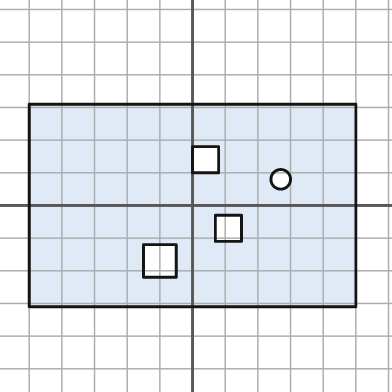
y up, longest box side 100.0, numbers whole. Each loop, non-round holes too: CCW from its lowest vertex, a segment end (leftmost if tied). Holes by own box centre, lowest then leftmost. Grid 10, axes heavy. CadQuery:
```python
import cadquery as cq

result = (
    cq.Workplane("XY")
    .moveTo(-50.0, -31.0)
    .lineTo(50.0, -31.0)
    .lineTo(50.0, 31.0)
    .lineTo(-50.0, 31.0)
    .close()
    .moveTo(-15.0, -22.0)
    .lineTo(-5.0, -22.0)
    .lineTo(-5.0, -12.0)
    .lineTo(-15.0, -12.0)
    .close()
    .moveTo(7.0, -11.0)
    .lineTo(15.0, -11.0)
    .lineTo(15.0, -3.0)
    .lineTo(7.0, -3.0)
    .close()
    .moveTo(27.0, 8.0)
    .circle(3.0)
    .moveTo(0.0, 10.0)
    .lineTo(8.0, 10.0)
    .lineTo(8.0, 18.0)
    .lineTo(0.0, 18.0)
    .close()
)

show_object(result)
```